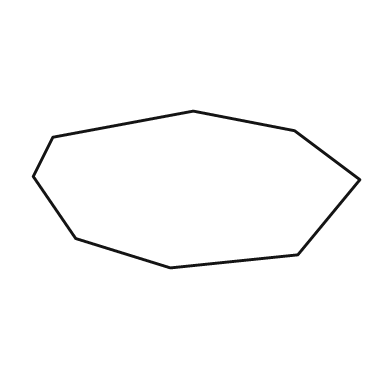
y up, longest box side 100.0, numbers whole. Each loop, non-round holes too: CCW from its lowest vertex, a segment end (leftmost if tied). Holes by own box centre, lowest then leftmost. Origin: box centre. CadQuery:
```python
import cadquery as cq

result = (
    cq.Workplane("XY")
    .moveTo(-8.0, -24.0)
    .lineTo(31.0, -20.0)
    .lineTo(50.0, 3.0)
    .lineTo(30.0, 18.0)
    .lineTo(-1.0, 24.0)
    .lineTo(-44.0, 16.0)
    .lineTo(-50.0, 4.0)
    .lineTo(-37.0, -15.0)
    .close()
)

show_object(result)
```